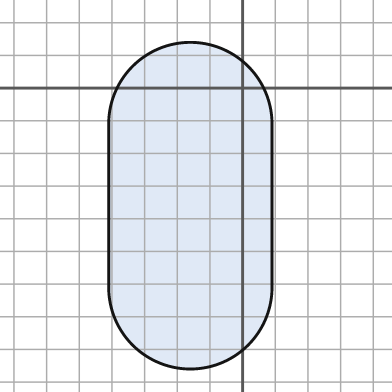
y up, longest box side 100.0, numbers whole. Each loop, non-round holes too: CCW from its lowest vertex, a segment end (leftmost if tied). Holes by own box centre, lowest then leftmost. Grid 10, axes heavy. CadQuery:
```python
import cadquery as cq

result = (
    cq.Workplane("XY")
    .moveTo(-41.0, -61.0)
    .threePointArc((-16.0, -86.0), (9.0, -61.0))
    .lineTo(9.0, -11.0)
    .threePointArc((-16.0, 14.0), (-41.0, -11.0))
    .close()
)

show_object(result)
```